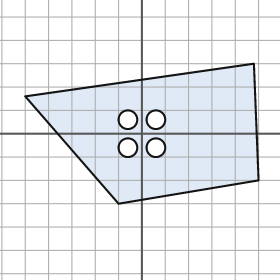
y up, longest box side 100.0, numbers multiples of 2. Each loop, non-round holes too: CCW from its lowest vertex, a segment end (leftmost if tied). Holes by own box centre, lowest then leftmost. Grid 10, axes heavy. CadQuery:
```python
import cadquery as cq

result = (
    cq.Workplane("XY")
    .moveTo(-10.0, -30.0)
    .lineTo(50.0, -20.0)
    .lineTo(48.0, 30.0)
    .lineTo(-50.0, 16.0)
    .close()
    .moveTo(-6.0, -6.0)
    .circle(4.0)
    .moveTo(6.0, -6.0)
    .circle(4.0)
    .moveTo(-6.0, 6.0)
    .circle(4.0)
    .moveTo(6.0, 6.0)
    .circle(4.0)
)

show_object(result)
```